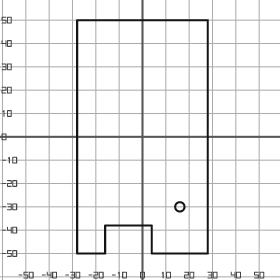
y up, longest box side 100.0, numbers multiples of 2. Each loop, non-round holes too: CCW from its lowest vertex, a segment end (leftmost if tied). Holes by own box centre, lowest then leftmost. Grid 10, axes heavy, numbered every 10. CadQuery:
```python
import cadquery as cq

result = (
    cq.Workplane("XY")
    .moveTo(-28.0, -50.0)
    .lineTo(-16.0, -50.0)
    .lineTo(-16.0, -38.0)
    .lineTo(4.0, -38.0)
    .lineTo(4.0, -50.0)
    .lineTo(28.0, -50.0)
    .lineTo(28.0, 50.0)
    .lineTo(-28.0, 50.0)
    .close()
    .moveTo(16.0, -30.0)
    .circle(2.0)
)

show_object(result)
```